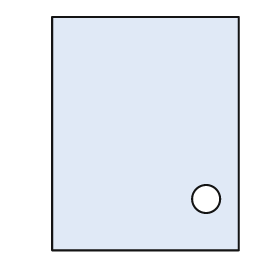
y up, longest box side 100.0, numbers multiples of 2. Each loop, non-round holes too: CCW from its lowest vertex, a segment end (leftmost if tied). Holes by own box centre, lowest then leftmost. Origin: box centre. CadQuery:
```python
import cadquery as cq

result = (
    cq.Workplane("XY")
    .moveTo(-40.0, -50.0)
    .lineTo(40.0, -50.0)
    .lineTo(40.0, 50.0)
    .lineTo(-40.0, 50.0)
    .close()
    .moveTo(26.0, -28.0)
    .circle(6.0)
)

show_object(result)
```